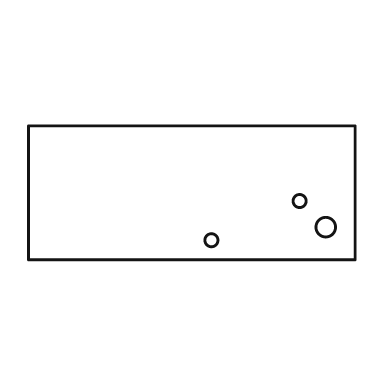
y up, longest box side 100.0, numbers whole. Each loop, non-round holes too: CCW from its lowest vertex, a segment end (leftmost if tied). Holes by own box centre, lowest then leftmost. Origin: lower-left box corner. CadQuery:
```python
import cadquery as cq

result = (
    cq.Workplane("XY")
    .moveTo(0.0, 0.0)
    .lineTo(100.0, 0.0)
    .lineTo(100.0, 41.0)
    .lineTo(0.0, 41.0)
    .close()
    .moveTo(56.0, 6.0)
    .circle(2.0)
    .moveTo(91.0, 10.0)
    .circle(3.0)
    .moveTo(83.0, 18.0)
    .circle(2.0)
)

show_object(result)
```